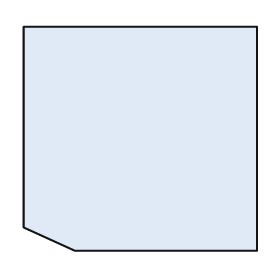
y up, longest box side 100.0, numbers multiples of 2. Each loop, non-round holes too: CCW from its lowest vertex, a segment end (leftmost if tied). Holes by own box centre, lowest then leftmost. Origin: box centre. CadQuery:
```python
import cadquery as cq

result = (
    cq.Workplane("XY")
    .moveTo(-28.0, -48.0)
    .lineTo(50.0, -48.0)
    .lineTo(50.0, 48.0)
    .lineTo(-50.0, 48.0)
    .lineTo(-50.0, -38.0)
    .close()
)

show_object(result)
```